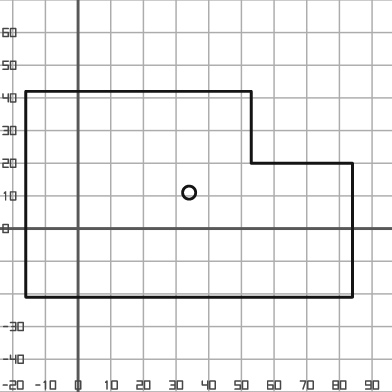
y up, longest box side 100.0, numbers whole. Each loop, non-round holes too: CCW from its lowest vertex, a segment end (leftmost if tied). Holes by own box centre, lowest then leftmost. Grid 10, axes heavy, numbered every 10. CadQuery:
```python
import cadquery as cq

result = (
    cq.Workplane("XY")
    .moveTo(-16.0, -21.0)
    .lineTo(84.0, -21.0)
    .lineTo(84.0, 20.0)
    .lineTo(53.0, 20.0)
    .lineTo(53.0, 42.0)
    .lineTo(-16.0, 42.0)
    .close()
    .moveTo(34.0, 11.0)
    .circle(2.0)
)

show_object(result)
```